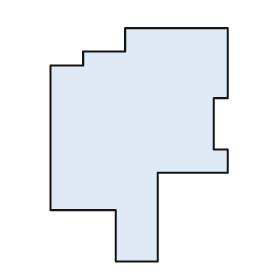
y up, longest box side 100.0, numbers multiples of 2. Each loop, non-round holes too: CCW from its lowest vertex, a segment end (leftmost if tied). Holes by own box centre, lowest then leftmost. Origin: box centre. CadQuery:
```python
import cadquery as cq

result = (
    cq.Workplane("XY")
    .moveTo(-10.0, -50.0)
    .lineTo(8.0, -50.0)
    .lineTo(8.0, -12.0)
    .lineTo(38.0, -12.0)
    .lineTo(38.0, -2.0)
    .lineTo(32.0, -2.0)
    .lineTo(32.0, 20.0)
    .lineTo(38.0, 20.0)
    .lineTo(38.0, 50.0)
    .lineTo(-6.0, 50.0)
    .lineTo(-6.0, 40.0)
    .lineTo(-24.0, 40.0)
    .lineTo(-24.0, 34.0)
    .lineTo(-38.0, 34.0)
    .lineTo(-38.0, -28.0)
    .lineTo(-10.0, -28.0)
    .close()
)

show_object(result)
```